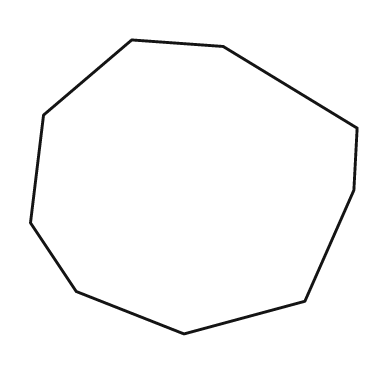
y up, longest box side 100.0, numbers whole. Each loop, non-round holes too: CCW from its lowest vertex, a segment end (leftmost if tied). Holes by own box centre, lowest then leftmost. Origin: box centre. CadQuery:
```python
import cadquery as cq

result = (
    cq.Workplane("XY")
    .moveTo(-3.0, -45.0)
    .lineTo(34.0, -35.0)
    .lineTo(49.0, -1.0)
    .lineTo(50.0, 18.0)
    .lineTo(9.0, 43.0)
    .lineTo(-19.0, 45.0)
    .lineTo(-46.0, 22.0)
    .lineTo(-50.0, -11.0)
    .lineTo(-36.0, -32.0)
    .close()
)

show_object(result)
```